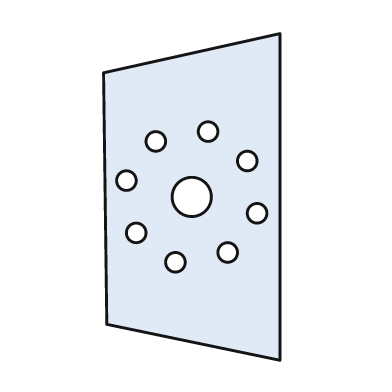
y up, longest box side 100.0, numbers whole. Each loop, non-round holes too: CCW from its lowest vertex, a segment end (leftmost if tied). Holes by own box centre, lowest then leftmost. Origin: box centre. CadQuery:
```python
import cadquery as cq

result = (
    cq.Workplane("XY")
    .moveTo(27.0, -50.0)
    .lineTo(27.0, 50.0)
    .lineTo(-27.0, 38.0)
    .lineTo(-26.0, -39.0)
    .close()
    .moveTo(-5.0, -20.0)
    .circle(3.0)
    .moveTo(11.0, -17.0)
    .circle(3.0)
    .moveTo(-17.0, -11.0)
    .circle(3.0)
    .moveTo(20.0, -5.0)
    .circle(3.0)
    .moveTo(0.0, 0.0)
    .circle(6.0)
    .moveTo(-20.0, 5.0)
    .circle(3.0)
    .moveTo(17.0, 11.0)
    .circle(3.0)
    .moveTo(-11.0, 17.0)
    .circle(3.0)
    .moveTo(5.0, 20.0)
    .circle(3.0)
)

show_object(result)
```